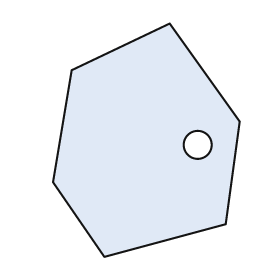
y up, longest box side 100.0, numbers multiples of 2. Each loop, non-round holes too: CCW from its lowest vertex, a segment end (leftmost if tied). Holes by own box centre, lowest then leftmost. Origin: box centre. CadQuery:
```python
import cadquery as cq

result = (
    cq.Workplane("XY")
    .moveTo(-18.0, -50.0)
    .lineTo(34.0, -36.0)
    .lineTo(40.0, 8.0)
    .lineTo(10.0, 50.0)
    .lineTo(-32.0, 30.0)
    .lineTo(-40.0, -18.0)
    .close()
    .moveTo(22.0, -2.0)
    .circle(6.0)
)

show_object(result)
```